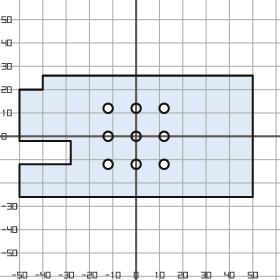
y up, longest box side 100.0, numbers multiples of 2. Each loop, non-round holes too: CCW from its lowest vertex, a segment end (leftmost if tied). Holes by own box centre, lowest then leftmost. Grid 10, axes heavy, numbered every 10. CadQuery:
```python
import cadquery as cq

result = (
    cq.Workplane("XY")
    .moveTo(-50.0, -26.0)
    .lineTo(50.0, -26.0)
    .lineTo(50.0, 26.0)
    .lineTo(-40.0, 26.0)
    .lineTo(-40.0, 20.0)
    .lineTo(-50.0, 20.0)
    .lineTo(-50.0, -2.0)
    .lineTo(-28.0, -2.0)
    .lineTo(-28.0, -12.0)
    .lineTo(-50.0, -12.0)
    .close()
    .moveTo(-12.0, -12.0)
    .circle(2.0)
    .moveTo(0.0, -12.0)
    .circle(2.0)
    .moveTo(12.0, -12.0)
    .circle(2.0)
    .moveTo(-12.0, 0.0)
    .circle(2.0)
    .moveTo(0.0, 0.0)
    .circle(2.0)
    .moveTo(12.0, 0.0)
    .circle(2.0)
    .moveTo(-12.0, 12.0)
    .circle(2.0)
    .moveTo(0.0, 12.0)
    .circle(2.0)
    .moveTo(12.0, 12.0)
    .circle(2.0)
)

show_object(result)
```